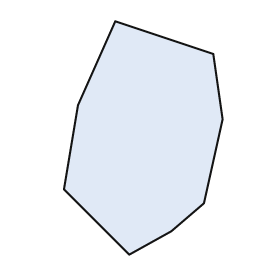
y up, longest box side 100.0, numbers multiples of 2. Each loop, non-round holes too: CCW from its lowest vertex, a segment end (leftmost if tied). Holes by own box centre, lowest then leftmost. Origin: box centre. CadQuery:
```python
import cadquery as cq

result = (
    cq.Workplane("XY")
    .moveTo(-6.0, -50.0)
    .lineTo(12.0, -40.0)
    .lineTo(26.0, -28.0)
    .lineTo(34.0, 8.0)
    .lineTo(30.0, 36.0)
    .lineTo(-12.0, 50.0)
    .lineTo(-28.0, 14.0)
    .lineTo(-34.0, -22.0)
    .close()
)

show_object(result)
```